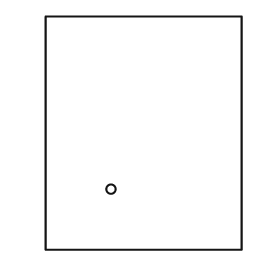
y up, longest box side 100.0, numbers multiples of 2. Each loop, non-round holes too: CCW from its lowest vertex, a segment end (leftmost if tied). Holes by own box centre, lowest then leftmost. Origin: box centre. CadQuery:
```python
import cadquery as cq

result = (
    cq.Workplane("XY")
    .moveTo(-42.0, -50.0)
    .lineTo(42.0, -50.0)
    .lineTo(42.0, 50.0)
    .lineTo(-42.0, 50.0)
    .close()
    .moveTo(-14.0, -24.0)
    .circle(2.0)
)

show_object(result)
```